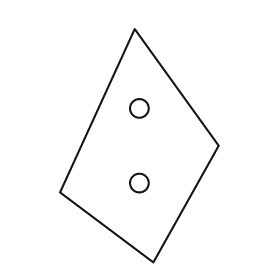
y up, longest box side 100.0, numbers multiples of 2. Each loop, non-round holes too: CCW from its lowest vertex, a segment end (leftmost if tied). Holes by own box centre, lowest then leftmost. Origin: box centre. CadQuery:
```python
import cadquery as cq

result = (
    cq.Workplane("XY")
    .moveTo(6.0, -50.0)
    .lineTo(34.0, 0.0)
    .lineTo(-2.0, 50.0)
    .lineTo(-34.0, -20.0)
    .close()
    .moveTo(0.0, -16.0)
    .circle(4.0)
    .moveTo(0.0, 16.0)
    .circle(4.0)
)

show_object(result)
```